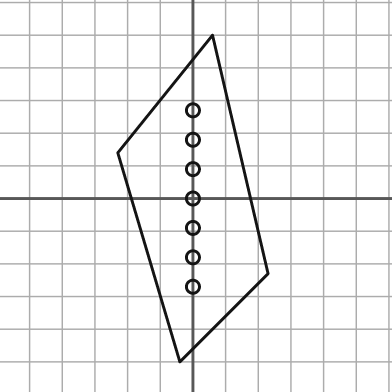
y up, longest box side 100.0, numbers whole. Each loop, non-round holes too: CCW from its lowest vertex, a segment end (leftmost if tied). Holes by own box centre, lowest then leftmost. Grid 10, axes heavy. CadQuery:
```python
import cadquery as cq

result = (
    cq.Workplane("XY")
    .moveTo(-4.0, -50.0)
    .lineTo(23.0, -23.0)
    .lineTo(6.0, 50.0)
    .lineTo(-23.0, 14.0)
    .close()
    .moveTo(0.0, -27.0)
    .circle(2.0)
    .moveTo(0.0, -18.0)
    .circle(2.0)
    .moveTo(0.0, -9.0)
    .circle(2.0)
    .moveTo(0.0, 0.0)
    .circle(2.0)
    .moveTo(0.0, 9.0)
    .circle(2.0)
    .moveTo(0.0, 18.0)
    .circle(2.0)
    .moveTo(0.0, 27.0)
    .circle(2.0)
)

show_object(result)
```